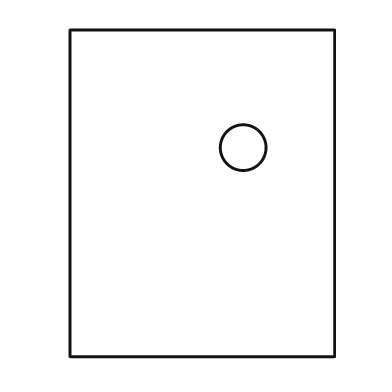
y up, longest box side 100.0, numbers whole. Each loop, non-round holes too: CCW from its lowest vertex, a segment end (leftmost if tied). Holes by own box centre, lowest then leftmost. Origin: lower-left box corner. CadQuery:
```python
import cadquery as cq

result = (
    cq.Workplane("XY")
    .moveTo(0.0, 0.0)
    .lineTo(81.0, 0.0)
    .lineTo(81.0, 100.0)
    .lineTo(0.0, 100.0)
    .close()
    .moveTo(53.0, 64.0)
    .circle(7.0)
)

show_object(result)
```